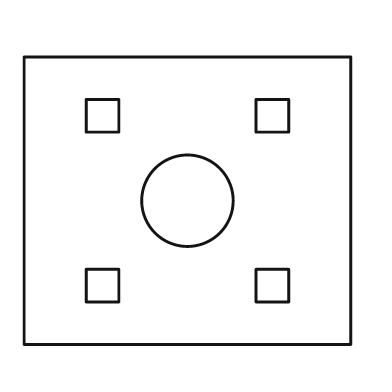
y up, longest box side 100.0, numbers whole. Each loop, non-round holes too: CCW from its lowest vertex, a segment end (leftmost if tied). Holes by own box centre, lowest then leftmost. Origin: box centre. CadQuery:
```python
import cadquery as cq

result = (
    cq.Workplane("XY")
    .moveTo(-50.0, -44.0)
    .lineTo(50.0, -44.0)
    .lineTo(50.0, 44.0)
    .lineTo(-50.0, 44.0)
    .close()
    .moveTo(-31.0, -31.0)
    .lineTo(-21.0, -31.0)
    .lineTo(-21.0, -21.0)
    .lineTo(-31.0, -21.0)
    .close()
    .moveTo(21.0, -31.0)
    .lineTo(31.0, -31.0)
    .lineTo(31.0, -21.0)
    .lineTo(21.0, -21.0)
    .close()
    .moveTo(0.0, 0.0)
    .circle(14.0)
    .moveTo(-31.0, 21.0)
    .lineTo(-21.0, 21.0)
    .lineTo(-21.0, 31.0)
    .lineTo(-31.0, 31.0)
    .close()
    .moveTo(21.0, 21.0)
    .lineTo(31.0, 21.0)
    .lineTo(31.0, 31.0)
    .lineTo(21.0, 31.0)
    .close()
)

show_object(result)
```